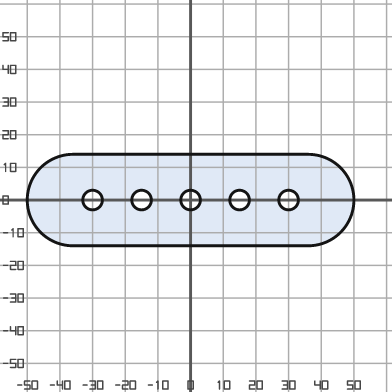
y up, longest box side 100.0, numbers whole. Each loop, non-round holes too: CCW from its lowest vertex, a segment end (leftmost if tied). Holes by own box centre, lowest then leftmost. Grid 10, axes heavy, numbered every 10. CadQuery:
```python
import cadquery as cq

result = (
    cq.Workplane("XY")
    .moveTo(-36.0, -14.0)
    .lineTo(36.0, -14.0)
    .threePointArc((50.0, 0.0), (36.0, 14.0))
    .lineTo(-36.0, 14.0)
    .threePointArc((-50.0, 0.0), (-36.0, -14.0))
    .close()
    .moveTo(-30.0, 0.0)
    .circle(3.0)
    .moveTo(-15.0, 0.0)
    .circle(3.0)
    .moveTo(0.0, 0.0)
    .circle(3.0)
    .moveTo(15.0, 0.0)
    .circle(3.0)
    .moveTo(30.0, 0.0)
    .circle(3.0)
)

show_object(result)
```